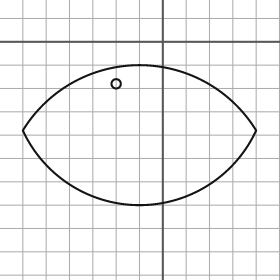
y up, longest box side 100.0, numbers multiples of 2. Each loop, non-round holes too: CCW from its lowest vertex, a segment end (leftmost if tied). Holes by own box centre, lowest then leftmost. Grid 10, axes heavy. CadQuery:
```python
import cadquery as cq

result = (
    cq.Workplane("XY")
    .moveTo(-60.0, -38.0)
    .threePointArc((-10.0, -70.0), (40.0, -38.0))
    .threePointArc((-10.0, -10.0), (-60.0, -38.0))
    .close()
    .moveTo(-20.0, -18.0)
    .circle(2.0)
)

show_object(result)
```